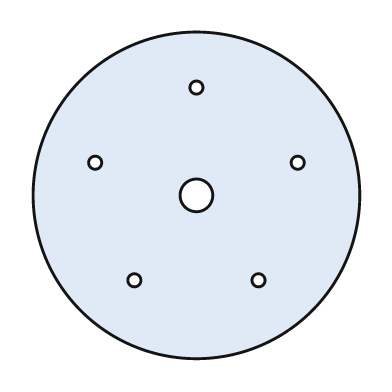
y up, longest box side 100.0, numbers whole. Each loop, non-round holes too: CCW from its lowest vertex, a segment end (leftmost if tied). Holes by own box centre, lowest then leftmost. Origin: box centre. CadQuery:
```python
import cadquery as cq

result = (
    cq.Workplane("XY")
    .moveTo(0.0, 0.0)
    .circle(50.0)
    .moveTo(-19.0, -26.0)
    .circle(2.0)
    .moveTo(19.0, -26.0)
    .circle(2.0)
    .moveTo(0.0, 0.0)
    .circle(5.0)
    .moveTo(-31.0, 10.0)
    .circle(2.0)
    .moveTo(31.0, 10.0)
    .circle(2.0)
    .moveTo(0.0, 33.0)
    .circle(2.0)
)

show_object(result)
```